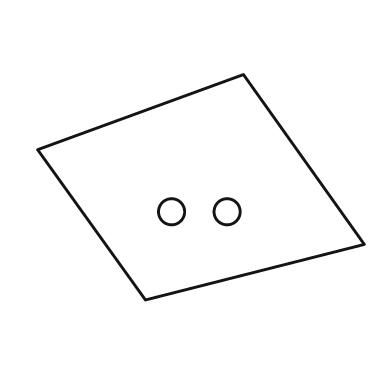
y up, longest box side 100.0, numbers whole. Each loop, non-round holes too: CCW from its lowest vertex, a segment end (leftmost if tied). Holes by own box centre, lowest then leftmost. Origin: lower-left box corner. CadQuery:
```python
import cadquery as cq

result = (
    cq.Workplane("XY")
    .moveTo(33.0, 0.0)
    .lineTo(100.0, 17.0)
    .lineTo(63.0, 69.0)
    .lineTo(0.0, 46.0)
    .close()
    .moveTo(41.0, 27.0)
    .circle(4.0)
    .moveTo(58.0, 27.0)
    .circle(4.0)
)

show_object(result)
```